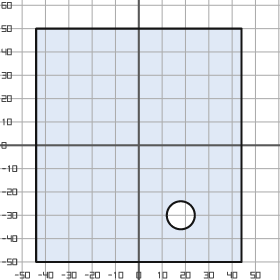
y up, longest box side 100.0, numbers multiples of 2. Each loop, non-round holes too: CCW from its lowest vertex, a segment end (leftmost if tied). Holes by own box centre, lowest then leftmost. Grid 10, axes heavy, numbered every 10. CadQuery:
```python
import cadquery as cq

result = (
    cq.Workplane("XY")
    .moveTo(-44.0, -50.0)
    .lineTo(44.0, -50.0)
    .lineTo(44.0, 50.0)
    .lineTo(-44.0, 50.0)
    .close()
    .moveTo(18.0, -30.0)
    .circle(6.0)
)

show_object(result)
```